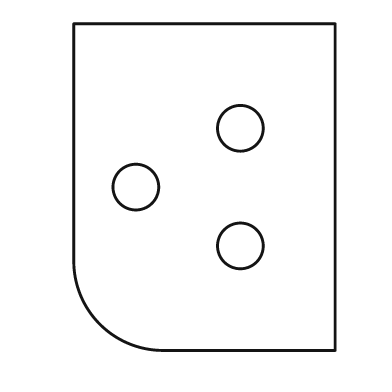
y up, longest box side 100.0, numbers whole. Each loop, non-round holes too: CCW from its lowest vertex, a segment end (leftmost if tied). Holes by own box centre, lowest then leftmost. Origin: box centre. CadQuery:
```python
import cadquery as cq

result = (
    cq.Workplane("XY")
    .moveTo(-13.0, -50.0)
    .lineTo(40.0, -50.0)
    .lineTo(40.0, 50.0)
    .lineTo(-40.0, 50.0)
    .lineTo(-40.0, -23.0)
    .threePointArc((-32.0, -42.0), (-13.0, -50.0))
    .close()
    .moveTo(11.0, -18.0)
    .circle(7.0)
    .moveTo(-21.0, 0.0)
    .circle(7.0)
    .moveTo(11.0, 18.0)
    .circle(7.0)
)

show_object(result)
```